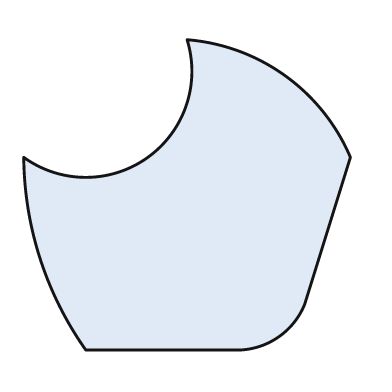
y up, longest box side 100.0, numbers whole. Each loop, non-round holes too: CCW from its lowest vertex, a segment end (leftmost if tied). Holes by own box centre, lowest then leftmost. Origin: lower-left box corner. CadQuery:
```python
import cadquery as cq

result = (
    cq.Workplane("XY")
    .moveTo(19.0, 0.0)
    .lineTo(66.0, 0.0)
    .threePointArc((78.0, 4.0), (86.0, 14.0))
    .lineTo(100.0, 59.0)
    .threePointArc((80.0, 84.0), (50.0, 95.0))
    .threePointArc((38.0, 59.0), (0.0, 59.0))
    .threePointArc((5.0, 28.0), (19.0, 0.0))
    .close()
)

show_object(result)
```